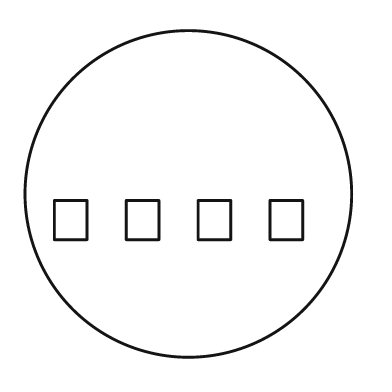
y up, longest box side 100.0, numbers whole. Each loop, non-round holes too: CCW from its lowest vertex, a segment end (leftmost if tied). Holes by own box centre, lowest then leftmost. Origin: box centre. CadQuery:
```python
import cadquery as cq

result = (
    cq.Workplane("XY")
    .moveTo(0.0, 0.0)
    .circle(50.0)
    .moveTo(-41.0, -14.0)
    .lineTo(-31.0, -14.0)
    .lineTo(-31.0, -2.0)
    .lineTo(-41.0, -2.0)
    .close()
    .moveTo(-19.0, -14.0)
    .lineTo(-9.0, -14.0)
    .lineTo(-9.0, -2.0)
    .lineTo(-19.0, -2.0)
    .close()
    .moveTo(3.0, -14.0)
    .lineTo(13.0, -14.0)
    .lineTo(13.0, -2.0)
    .lineTo(3.0, -2.0)
    .close()
    .moveTo(25.0, -14.0)
    .lineTo(35.0, -14.0)
    .lineTo(35.0, -2.0)
    .lineTo(25.0, -2.0)
    .close()
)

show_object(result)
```